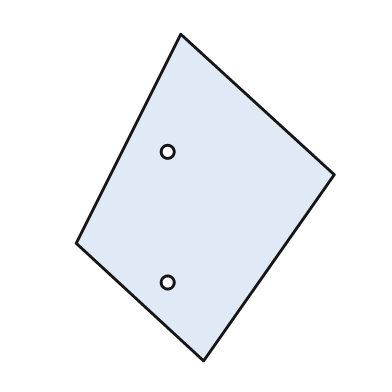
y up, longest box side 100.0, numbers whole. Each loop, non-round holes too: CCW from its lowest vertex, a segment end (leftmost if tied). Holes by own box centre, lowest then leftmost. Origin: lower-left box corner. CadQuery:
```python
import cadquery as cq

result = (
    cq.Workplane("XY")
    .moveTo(39.0, 0.0)
    .lineTo(79.0, 57.0)
    .lineTo(32.0, 100.0)
    .lineTo(0.0, 36.0)
    .close()
    .moveTo(28.0, 24.0)
    .circle(2.0)
    .moveTo(28.0, 64.0)
    .circle(2.0)
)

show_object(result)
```